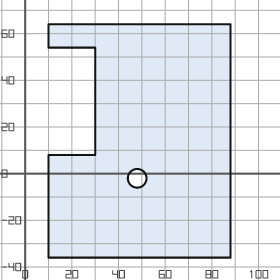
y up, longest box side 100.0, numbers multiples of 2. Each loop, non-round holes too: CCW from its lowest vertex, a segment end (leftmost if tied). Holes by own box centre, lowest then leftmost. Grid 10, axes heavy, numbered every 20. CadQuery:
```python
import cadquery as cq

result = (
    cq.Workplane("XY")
    .moveTo(10.0, -36.0)
    .lineTo(88.0, -36.0)
    .lineTo(88.0, 64.0)
    .lineTo(10.0, 64.0)
    .lineTo(10.0, 54.0)
    .lineTo(30.0, 54.0)
    .lineTo(30.0, 8.0)
    .lineTo(10.0, 8.0)
    .close()
    .moveTo(48.0, -2.0)
    .circle(4.0)
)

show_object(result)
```